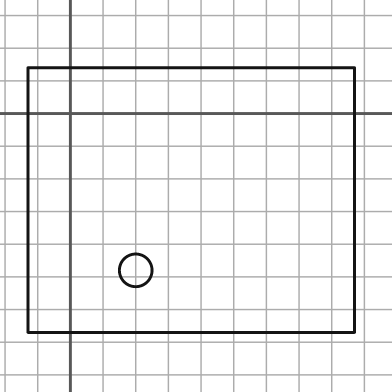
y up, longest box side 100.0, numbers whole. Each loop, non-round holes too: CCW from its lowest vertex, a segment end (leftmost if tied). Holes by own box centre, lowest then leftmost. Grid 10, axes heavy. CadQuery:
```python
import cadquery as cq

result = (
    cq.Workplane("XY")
    .moveTo(-13.0, -67.0)
    .lineTo(87.0, -67.0)
    .lineTo(87.0, 14.0)
    .lineTo(-13.0, 14.0)
    .close()
    .moveTo(20.0, -48.0)
    .circle(5.0)
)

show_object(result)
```